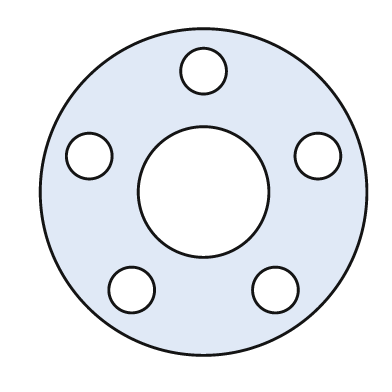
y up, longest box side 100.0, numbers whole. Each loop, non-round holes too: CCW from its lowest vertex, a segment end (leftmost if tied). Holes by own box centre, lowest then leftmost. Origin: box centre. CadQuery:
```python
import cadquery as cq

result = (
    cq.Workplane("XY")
    .moveTo(0.0, 0.0)
    .circle(50.0)
    .moveTo(-22.0, -30.0)
    .circle(7.0)
    .moveTo(22.0, -30.0)
    .circle(7.0)
    .moveTo(0.0, 0.0)
    .circle(20.0)
    .moveTo(-35.0, 11.0)
    .circle(7.0)
    .moveTo(35.0, 11.0)
    .circle(7.0)
    .moveTo(0.0, 37.0)
    .circle(7.0)
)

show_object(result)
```